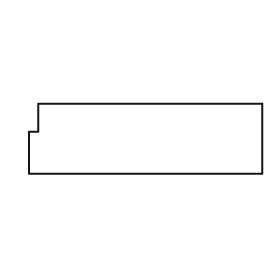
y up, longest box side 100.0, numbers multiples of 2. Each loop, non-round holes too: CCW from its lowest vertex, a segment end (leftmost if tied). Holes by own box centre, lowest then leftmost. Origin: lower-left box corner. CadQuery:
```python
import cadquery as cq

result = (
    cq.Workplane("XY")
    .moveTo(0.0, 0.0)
    .lineTo(100.0, 0.0)
    .lineTo(100.0, 30.0)
    .lineTo(4.0, 30.0)
    .lineTo(4.0, 18.0)
    .lineTo(0.0, 18.0)
    .close()
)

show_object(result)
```